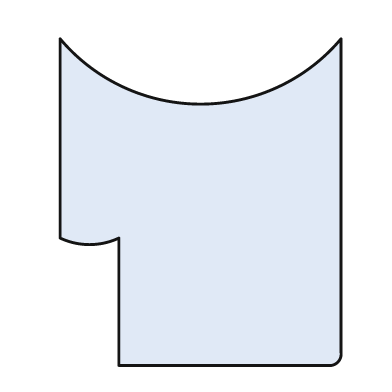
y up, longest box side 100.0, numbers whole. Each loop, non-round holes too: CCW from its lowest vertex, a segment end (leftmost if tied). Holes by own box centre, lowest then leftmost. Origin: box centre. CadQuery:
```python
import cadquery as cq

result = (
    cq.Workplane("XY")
    .moveTo(-25.0, -50.0)
    .lineTo(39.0, -50.0)
    .threePointArc((42.0, -49.0), (43.0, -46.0))
    .lineTo(43.0, 50.0)
    .threePointArc((0.0, 30.0), (-43.0, 50.0))
    .lineTo(-43.0, -11.0)
    .threePointArc((-34.0, -13.0), (-25.0, -11.0))
    .close()
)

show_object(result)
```